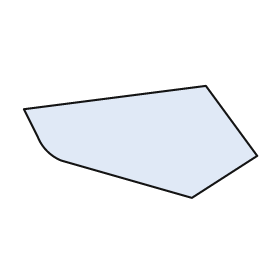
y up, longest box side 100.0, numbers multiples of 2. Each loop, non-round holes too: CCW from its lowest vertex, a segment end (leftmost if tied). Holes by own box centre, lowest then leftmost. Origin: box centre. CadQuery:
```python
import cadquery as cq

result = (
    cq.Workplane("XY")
    .moveTo(22.0, -24.0)
    .lineTo(50.0, -6.0)
    .lineTo(28.0, 24.0)
    .lineTo(-50.0, 14.0)
    .lineTo(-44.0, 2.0)
    .threePointArc((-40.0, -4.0), (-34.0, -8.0))
    .close()
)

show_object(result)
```